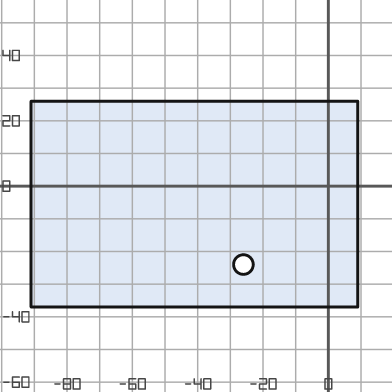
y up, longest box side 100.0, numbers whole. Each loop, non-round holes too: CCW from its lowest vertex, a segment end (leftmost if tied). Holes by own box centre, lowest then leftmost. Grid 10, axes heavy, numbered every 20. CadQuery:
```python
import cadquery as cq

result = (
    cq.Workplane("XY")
    .moveTo(-91.0, -37.0)
    .lineTo(9.0, -37.0)
    .lineTo(9.0, 26.0)
    .lineTo(-91.0, 26.0)
    .close()
    .moveTo(-26.0, -24.0)
    .circle(3.0)
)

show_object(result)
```